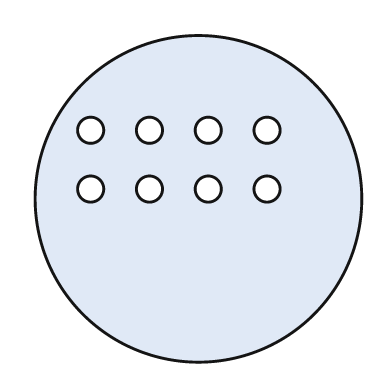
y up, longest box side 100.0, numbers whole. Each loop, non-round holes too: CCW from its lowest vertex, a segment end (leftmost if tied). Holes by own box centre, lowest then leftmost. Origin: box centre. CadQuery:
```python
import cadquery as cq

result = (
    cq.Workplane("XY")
    .moveTo(0.0, 0.0)
    .circle(50.0)
    .moveTo(-33.0, 3.0)
    .circle(4.0)
    .moveTo(-15.0, 3.0)
    .circle(4.0)
    .moveTo(3.0, 3.0)
    .circle(4.0)
    .moveTo(21.0, 3.0)
    .circle(4.0)
    .moveTo(-33.0, 21.0)
    .circle(4.0)
    .moveTo(-15.0, 21.0)
    .circle(4.0)
    .moveTo(3.0, 21.0)
    .circle(4.0)
    .moveTo(21.0, 21.0)
    .circle(4.0)
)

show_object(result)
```